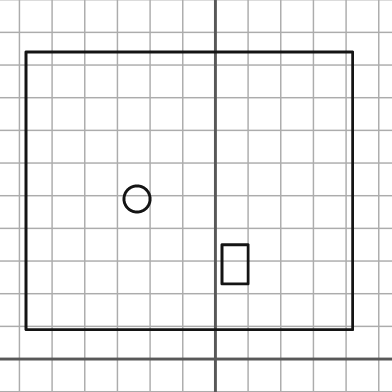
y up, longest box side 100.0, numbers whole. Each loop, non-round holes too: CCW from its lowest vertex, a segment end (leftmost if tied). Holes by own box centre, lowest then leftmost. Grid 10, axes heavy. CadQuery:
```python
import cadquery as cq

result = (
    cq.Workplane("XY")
    .moveTo(-58.0, 9.0)
    .lineTo(42.0, 9.0)
    .lineTo(42.0, 94.0)
    .lineTo(-58.0, 94.0)
    .close()
    .moveTo(2.0, 23.0)
    .lineTo(10.0, 23.0)
    .lineTo(10.0, 35.0)
    .lineTo(2.0, 35.0)
    .close()
    .moveTo(-24.0, 49.0)
    .circle(4.0)
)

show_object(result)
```